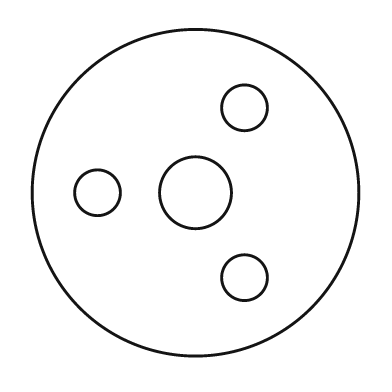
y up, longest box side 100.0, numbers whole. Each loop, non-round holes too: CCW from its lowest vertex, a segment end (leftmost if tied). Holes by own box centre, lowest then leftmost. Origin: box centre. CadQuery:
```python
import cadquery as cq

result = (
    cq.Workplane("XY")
    .moveTo(0.0, 0.0)
    .circle(50.0)
    .moveTo(15.0, -26.0)
    .circle(7.0)
    .moveTo(-30.0, 0.0)
    .circle(7.0)
    .moveTo(0.0, 0.0)
    .circle(11.0)
    .moveTo(15.0, 26.0)
    .circle(7.0)
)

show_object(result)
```